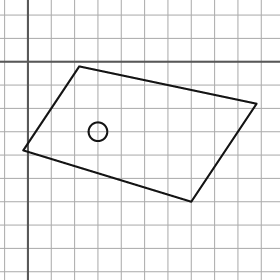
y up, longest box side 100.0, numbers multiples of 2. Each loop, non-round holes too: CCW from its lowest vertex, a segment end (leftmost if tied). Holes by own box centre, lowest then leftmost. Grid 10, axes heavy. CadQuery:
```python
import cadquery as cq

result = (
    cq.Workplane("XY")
    .moveTo(70.0, -60.0)
    .lineTo(98.0, -18.0)
    .lineTo(22.0, -2.0)
    .lineTo(-2.0, -38.0)
    .close()
    .moveTo(30.0, -30.0)
    .circle(4.0)
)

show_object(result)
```